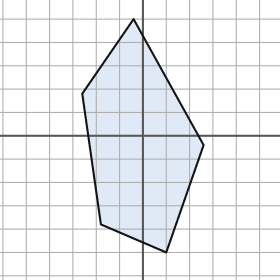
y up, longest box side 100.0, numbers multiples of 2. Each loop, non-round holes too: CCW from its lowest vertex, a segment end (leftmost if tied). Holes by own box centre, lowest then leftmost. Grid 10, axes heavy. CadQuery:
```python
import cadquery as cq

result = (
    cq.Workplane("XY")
    .moveTo(10.0, -50.0)
    .lineTo(26.0, -4.0)
    .lineTo(-4.0, 50.0)
    .lineTo(-26.0, 18.0)
    .lineTo(-18.0, -38.0)
    .close()
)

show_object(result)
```